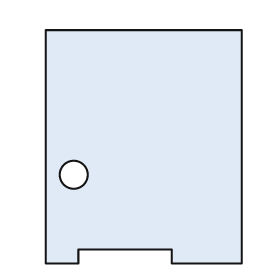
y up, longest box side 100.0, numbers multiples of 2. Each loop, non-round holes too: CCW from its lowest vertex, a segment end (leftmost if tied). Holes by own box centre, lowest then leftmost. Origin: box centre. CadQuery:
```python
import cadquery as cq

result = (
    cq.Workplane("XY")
    .moveTo(-42.0, -50.0)
    .lineTo(-28.0, -50.0)
    .lineTo(-28.0, -44.0)
    .lineTo(12.0, -44.0)
    .lineTo(12.0, -50.0)
    .lineTo(42.0, -50.0)
    .lineTo(42.0, 50.0)
    .lineTo(-42.0, 50.0)
    .close()
    .moveTo(-30.0, -12.0)
    .circle(6.0)
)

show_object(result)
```